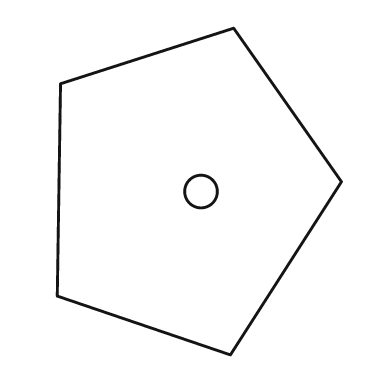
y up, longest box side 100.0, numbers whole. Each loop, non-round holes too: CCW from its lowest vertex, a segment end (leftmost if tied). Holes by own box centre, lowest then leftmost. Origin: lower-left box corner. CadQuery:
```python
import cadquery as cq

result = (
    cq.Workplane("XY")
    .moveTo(53.0, 0.0)
    .lineTo(87.0, 53.0)
    .lineTo(54.0, 100.0)
    .lineTo(1.0, 83.0)
    .lineTo(0.0, 18.0)
    .close()
    .moveTo(44.0, 50.0)
    .circle(5.0)
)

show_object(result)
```